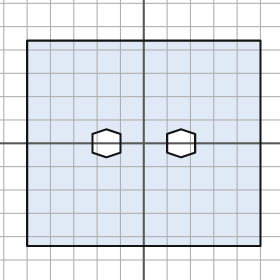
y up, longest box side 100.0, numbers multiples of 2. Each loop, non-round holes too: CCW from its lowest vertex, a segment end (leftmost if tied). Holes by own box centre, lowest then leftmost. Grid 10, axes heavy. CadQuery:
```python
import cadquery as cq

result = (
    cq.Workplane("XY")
    .moveTo(-50.0, -44.0)
    .lineTo(50.0, -44.0)
    .lineTo(50.0, 44.0)
    .lineTo(-50.0, 44.0)
    .close()
    .moveTo(-16.0, -6.0)
    .lineTo(-10.0, -4.0)
    .lineTo(-10.0, 4.0)
    .lineTo(-16.0, 6.0)
    .lineTo(-22.0, 4.0)
    .lineTo(-22.0, -4.0)
    .close()
    .moveTo(16.0, -6.0)
    .lineTo(22.0, -4.0)
    .lineTo(22.0, 4.0)
    .lineTo(16.0, 6.0)
    .lineTo(10.0, 4.0)
    .lineTo(10.0, -4.0)
    .close()
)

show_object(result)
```